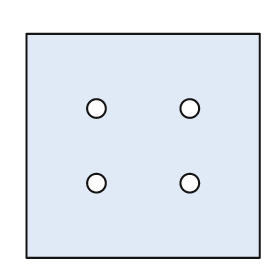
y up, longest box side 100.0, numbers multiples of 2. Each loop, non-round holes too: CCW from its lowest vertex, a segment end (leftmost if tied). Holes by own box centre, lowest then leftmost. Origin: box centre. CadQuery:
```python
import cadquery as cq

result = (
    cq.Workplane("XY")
    .moveTo(-50.0, -48.0)
    .lineTo(50.0, -48.0)
    .lineTo(50.0, 48.0)
    .lineTo(-50.0, 48.0)
    .close()
    .moveTo(-20.0, -16.0)
    .circle(4.0)
    .moveTo(20.0, -16.0)
    .circle(4.0)
    .moveTo(-20.0, 16.0)
    .circle(4.0)
    .moveTo(20.0, 16.0)
    .circle(4.0)
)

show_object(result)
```